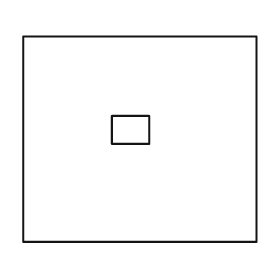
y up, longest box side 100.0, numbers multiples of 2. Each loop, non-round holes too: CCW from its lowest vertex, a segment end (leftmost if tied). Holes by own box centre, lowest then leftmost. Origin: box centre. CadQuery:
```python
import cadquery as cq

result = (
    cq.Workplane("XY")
    .moveTo(-50.0, -44.0)
    .lineTo(50.0, -44.0)
    .lineTo(50.0, 44.0)
    .lineTo(-50.0, 44.0)
    .close()
    .moveTo(-12.0, -2.0)
    .lineTo(4.0, -2.0)
    .lineTo(4.0, 10.0)
    .lineTo(-12.0, 10.0)
    .close()
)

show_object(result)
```